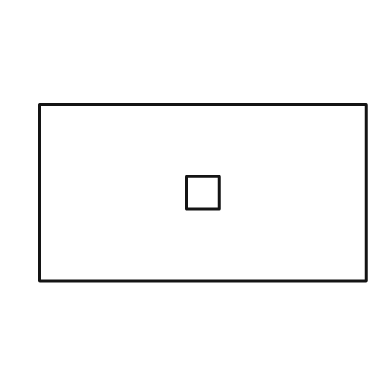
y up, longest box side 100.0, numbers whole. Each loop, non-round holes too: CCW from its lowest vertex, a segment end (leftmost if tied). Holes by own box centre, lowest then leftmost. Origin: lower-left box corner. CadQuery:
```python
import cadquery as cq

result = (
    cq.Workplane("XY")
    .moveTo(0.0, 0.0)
    .lineTo(100.0, 0.0)
    .lineTo(100.0, 54.0)
    .lineTo(0.0, 54.0)
    .close()
    .moveTo(45.0, 22.0)
    .lineTo(55.0, 22.0)
    .lineTo(55.0, 32.0)
    .lineTo(45.0, 32.0)
    .close()
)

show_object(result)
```